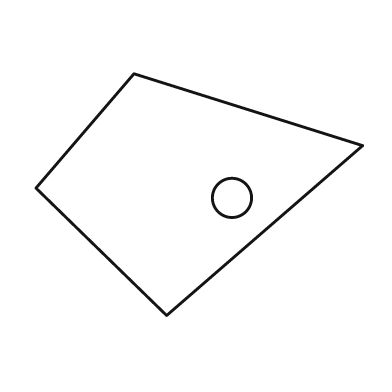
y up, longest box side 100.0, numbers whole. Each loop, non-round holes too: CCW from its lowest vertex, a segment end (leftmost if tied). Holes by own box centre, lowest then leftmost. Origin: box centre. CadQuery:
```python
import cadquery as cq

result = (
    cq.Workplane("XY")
    .moveTo(-10.0, -37.0)
    .lineTo(50.0, 15.0)
    .lineTo(-20.0, 37.0)
    .lineTo(-50.0, 2.0)
    .close()
    .moveTo(10.0, -1.0)
    .circle(6.0)
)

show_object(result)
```